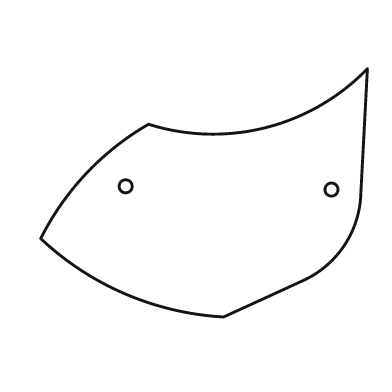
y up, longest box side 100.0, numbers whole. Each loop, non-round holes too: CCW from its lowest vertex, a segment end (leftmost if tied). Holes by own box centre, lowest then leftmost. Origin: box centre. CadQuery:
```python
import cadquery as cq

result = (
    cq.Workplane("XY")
    .moveTo(6.0, -38.0)
    .lineTo(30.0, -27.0)
    .threePointArc((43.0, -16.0), (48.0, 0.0))
    .lineTo(50.0, 38.0)
    .threePointArc((19.0, 20.0), (-17.0, 21.0))
    .threePointArc((-36.0, 6.0), (-50.0, -14.0))
    .threePointArc((-24.0, -31.0), (6.0, -38.0))
    .close()
    .moveTo(39.0, 1.0)
    .circle(2.0)
    .moveTo(-24.0, 2.0)
    .circle(2.0)
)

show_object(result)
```